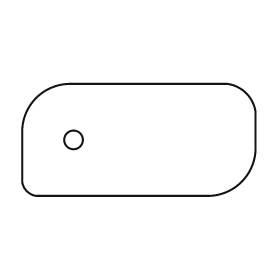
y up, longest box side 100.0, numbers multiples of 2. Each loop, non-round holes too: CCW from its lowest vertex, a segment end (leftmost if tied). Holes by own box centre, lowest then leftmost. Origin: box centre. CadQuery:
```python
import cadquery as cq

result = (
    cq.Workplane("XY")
    .moveTo(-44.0, -24.0)
    .lineTo(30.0, -24.0)
    .threePointArc((44.0, -18.0), (50.0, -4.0))
    .lineTo(50.0, 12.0)
    .threePointArc((46.0, 20.0), (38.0, 24.0))
    .lineTo(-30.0, 24.0)
    .threePointArc((-44.0, 18.0), (-50.0, 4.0))
    .lineTo(-50.0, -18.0)
    .threePointArc((-48.0, -22.0), (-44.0, -24.0))
    .close()
    .moveTo(-28.0, 0.0)
    .circle(4.0)
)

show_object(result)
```